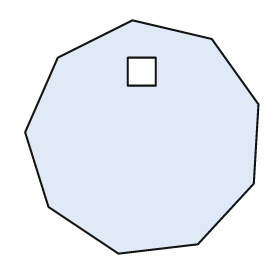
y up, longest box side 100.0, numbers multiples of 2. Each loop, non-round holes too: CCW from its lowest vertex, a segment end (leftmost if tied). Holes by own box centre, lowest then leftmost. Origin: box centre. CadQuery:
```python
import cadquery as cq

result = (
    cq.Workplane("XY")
    .moveTo(-10.0, -50.0)
    .lineTo(24.0, -46.0)
    .lineTo(48.0, -20.0)
    .lineTo(50.0, 14.0)
    .lineTo(30.0, 42.0)
    .lineTo(-4.0, 50.0)
    .lineTo(-36.0, 34.0)
    .lineTo(-50.0, 2.0)
    .lineTo(-40.0, -30.0)
    .close()
    .moveTo(-6.0, 22.0)
    .lineTo(6.0, 22.0)
    .lineTo(6.0, 34.0)
    .lineTo(-6.0, 34.0)
    .close()
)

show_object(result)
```